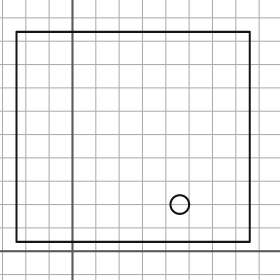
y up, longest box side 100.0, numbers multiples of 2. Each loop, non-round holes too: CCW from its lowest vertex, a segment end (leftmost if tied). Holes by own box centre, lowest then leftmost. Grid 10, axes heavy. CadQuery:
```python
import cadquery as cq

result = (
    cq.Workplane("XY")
    .moveTo(-24.0, 4.0)
    .lineTo(76.0, 4.0)
    .lineTo(76.0, 94.0)
    .lineTo(-24.0, 94.0)
    .close()
    .moveTo(46.0, 20.0)
    .circle(4.0)
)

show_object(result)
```